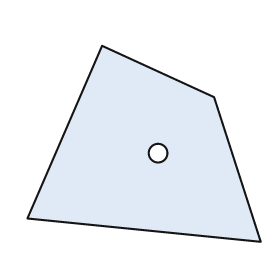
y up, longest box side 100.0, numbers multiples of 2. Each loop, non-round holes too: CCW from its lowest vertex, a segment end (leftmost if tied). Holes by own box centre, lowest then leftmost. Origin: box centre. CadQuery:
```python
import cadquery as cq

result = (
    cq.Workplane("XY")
    .moveTo(50.0, -42.0)
    .lineTo(30.0, 20.0)
    .lineTo(-18.0, 42.0)
    .lineTo(-50.0, -32.0)
    .close()
    .moveTo(6.0, -4.0)
    .circle(4.0)
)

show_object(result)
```